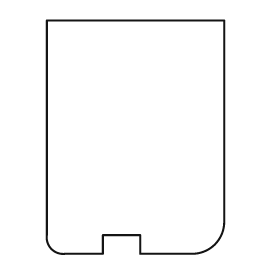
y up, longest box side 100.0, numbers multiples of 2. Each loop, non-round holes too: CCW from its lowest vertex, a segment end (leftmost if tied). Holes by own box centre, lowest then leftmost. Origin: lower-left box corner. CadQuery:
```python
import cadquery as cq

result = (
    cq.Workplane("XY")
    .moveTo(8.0, 0.0)
    .lineTo(24.0, 0.0)
    .lineTo(24.0, 8.0)
    .lineTo(40.0, 8.0)
    .lineTo(40.0, 0.0)
    .lineTo(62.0, 0.0)
    .threePointArc((72.0, 4.0), (76.0, 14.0))
    .lineTo(76.0, 100.0)
    .lineTo(0.0, 100.0)
    .lineTo(0.0, 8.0)
    .threePointArc((2.0, 2.0), (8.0, 0.0))
    .close()
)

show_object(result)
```